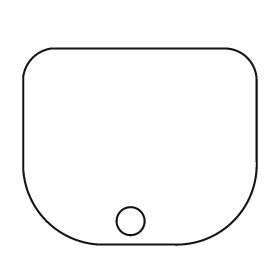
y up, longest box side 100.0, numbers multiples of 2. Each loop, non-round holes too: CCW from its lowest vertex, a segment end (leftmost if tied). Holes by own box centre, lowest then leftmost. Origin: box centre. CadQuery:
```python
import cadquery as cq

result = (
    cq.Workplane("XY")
    .moveTo(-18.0, -42.0)
    .lineTo(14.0, -42.0)
    .threePointArc((40.0, -32.0), (50.0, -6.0))
    .lineTo(50.0, 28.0)
    .threePointArc((46.0, 38.0), (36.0, 42.0))
    .lineTo(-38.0, 42.0)
    .threePointArc((-46.0, 38.0), (-50.0, 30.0))
    .lineTo(-50.0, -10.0)
    .threePointArc((-40.0, -32.0), (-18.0, -42.0))
    .close()
    .moveTo(-4.0, -32.0)
    .circle(6.0)
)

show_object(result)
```